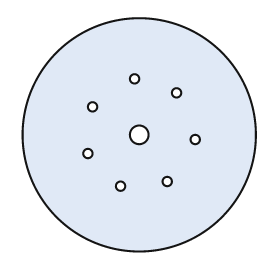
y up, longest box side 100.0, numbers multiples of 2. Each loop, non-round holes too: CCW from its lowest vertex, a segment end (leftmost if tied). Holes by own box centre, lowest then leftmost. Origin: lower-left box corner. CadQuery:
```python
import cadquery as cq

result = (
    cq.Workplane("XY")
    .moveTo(50.0, 50.0)
    .circle(50.0)
    .moveTo(42.0, 28.0)
    .circle(2.0)
    .moveTo(62.0, 30.0)
    .circle(2.0)
    .moveTo(28.0, 42.0)
    .circle(2.0)
    .moveTo(74.0, 48.0)
    .circle(2.0)
    .moveTo(50.0, 50.0)
    .circle(4.0)
    .moveTo(30.0, 62.0)
    .circle(2.0)
    .moveTo(66.0, 68.0)
    .circle(2.0)
    .moveTo(48.0, 74.0)
    .circle(2.0)
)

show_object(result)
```